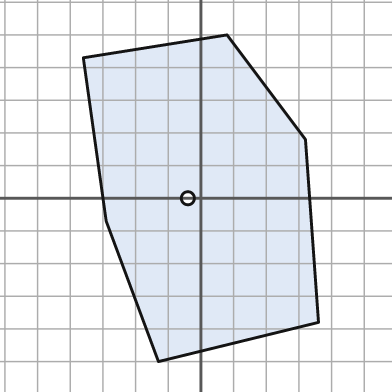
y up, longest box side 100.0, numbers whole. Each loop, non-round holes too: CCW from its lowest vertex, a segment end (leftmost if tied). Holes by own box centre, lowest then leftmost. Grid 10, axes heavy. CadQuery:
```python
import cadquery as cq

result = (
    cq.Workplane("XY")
    .moveTo(-13.0, -50.0)
    .lineTo(36.0, -38.0)
    .lineTo(32.0, 18.0)
    .lineTo(8.0, 50.0)
    .lineTo(-36.0, 43.0)
    .lineTo(-29.0, -7.0)
    .close()
    .moveTo(-4.0, 0.0)
    .circle(2.0)
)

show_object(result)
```